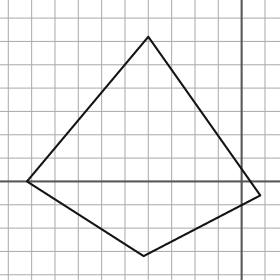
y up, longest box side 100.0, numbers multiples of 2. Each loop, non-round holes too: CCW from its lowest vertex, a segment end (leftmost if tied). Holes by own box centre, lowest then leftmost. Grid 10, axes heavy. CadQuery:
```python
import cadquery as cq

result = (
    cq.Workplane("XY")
    .moveTo(-42.0, -32.0)
    .lineTo(8.0, -6.0)
    .lineTo(-40.0, 62.0)
    .lineTo(-92.0, 0.0)
    .close()
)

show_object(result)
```